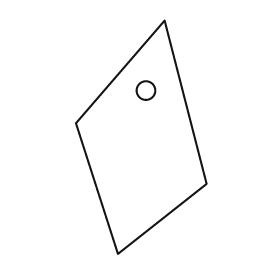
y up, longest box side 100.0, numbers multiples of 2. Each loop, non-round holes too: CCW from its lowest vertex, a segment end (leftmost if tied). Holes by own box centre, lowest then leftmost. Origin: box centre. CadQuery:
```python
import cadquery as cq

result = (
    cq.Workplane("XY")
    .moveTo(-10.0, -50.0)
    .lineTo(28.0, -20.0)
    .lineTo(10.0, 50.0)
    .lineTo(-28.0, 6.0)
    .close()
    .moveTo(2.0, 20.0)
    .circle(4.0)
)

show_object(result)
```